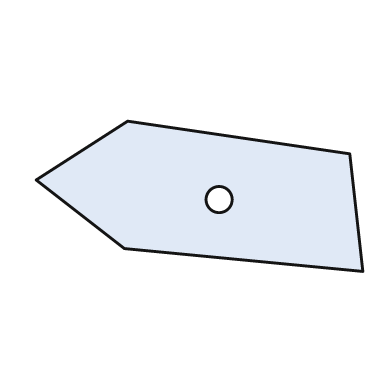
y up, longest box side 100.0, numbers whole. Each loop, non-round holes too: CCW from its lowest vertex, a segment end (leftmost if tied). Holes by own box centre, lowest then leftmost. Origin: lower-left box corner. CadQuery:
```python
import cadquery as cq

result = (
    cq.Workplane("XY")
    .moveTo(100.0, 0.0)
    .lineTo(96.0, 36.0)
    .lineTo(28.0, 46.0)
    .lineTo(0.0, 28.0)
    .lineTo(27.0, 7.0)
    .close()
    .moveTo(56.0, 22.0)
    .circle(4.0)
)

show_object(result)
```